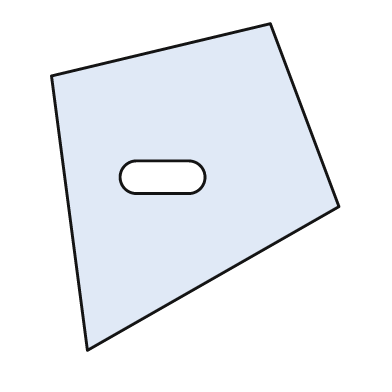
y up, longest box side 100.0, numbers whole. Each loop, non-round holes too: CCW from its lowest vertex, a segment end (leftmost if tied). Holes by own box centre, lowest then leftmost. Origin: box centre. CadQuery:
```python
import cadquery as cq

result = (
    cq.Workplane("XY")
    .moveTo(-33.0, -50.0)
    .lineTo(44.0, -6.0)
    .lineTo(23.0, 50.0)
    .lineTo(-44.0, 34.0)
    .close()
    .moveTo(-18.0, -2.0)
    .lineTo(-2.0, -2.0)
    .threePointArc((3.0, 3.0), (-2.0, 8.0))
    .lineTo(-18.0, 8.0)
    .threePointArc((-23.0, 3.0), (-18.0, -2.0))
    .close()
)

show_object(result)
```